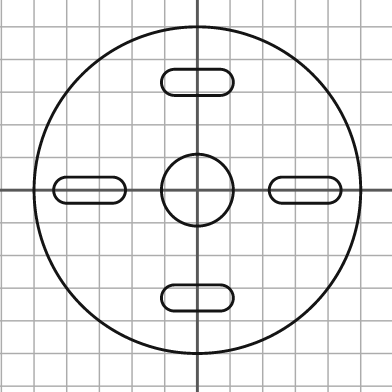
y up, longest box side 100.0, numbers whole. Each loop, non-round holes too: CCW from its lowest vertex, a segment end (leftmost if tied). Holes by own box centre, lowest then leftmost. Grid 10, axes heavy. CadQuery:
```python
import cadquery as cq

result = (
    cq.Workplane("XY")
    .moveTo(0.0, 0.0)
    .circle(50.0)
    .moveTo(-7.0, -37.0)
    .lineTo(7.0, -37.0)
    .threePointArc((11.0, -33.0), (7.0, -29.0))
    .lineTo(-7.0, -29.0)
    .threePointArc((-11.0, -33.0), (-7.0, -37.0))
    .close()
    .moveTo(-40.0, -4.0)
    .lineTo(-26.0, -4.0)
    .threePointArc((-22.0, 0.0), (-26.0, 4.0))
    .lineTo(-40.0, 4.0)
    .threePointArc((-44.0, 0.0), (-40.0, -4.0))
    .close()
    .moveTo(0.0, 0.0)
    .circle(11.0)
    .moveTo(26.0, -4.0)
    .lineTo(40.0, -4.0)
    .threePointArc((44.0, 0.0), (40.0, 4.0))
    .lineTo(26.0, 4.0)
    .threePointArc((22.0, 0.0), (26.0, -4.0))
    .close()
    .moveTo(-7.0, 29.0)
    .lineTo(7.0, 29.0)
    .threePointArc((11.0, 33.0), (7.0, 37.0))
    .lineTo(-7.0, 37.0)
    .threePointArc((-11.0, 33.0), (-7.0, 29.0))
    .close()
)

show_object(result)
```